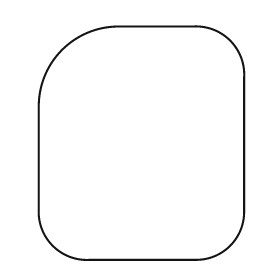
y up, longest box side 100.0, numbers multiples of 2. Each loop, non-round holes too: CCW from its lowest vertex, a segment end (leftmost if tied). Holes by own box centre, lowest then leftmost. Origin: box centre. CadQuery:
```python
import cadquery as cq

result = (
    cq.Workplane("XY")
    .moveTo(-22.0, -50.0)
    .lineTo(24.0, -50.0)
    .threePointArc((38.0, -44.0), (44.0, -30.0))
    .lineTo(44.0, 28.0)
    .threePointArc((38.0, 44.0), (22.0, 50.0))
    .lineTo(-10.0, 50.0)
    .threePointArc((-34.0, 40.0), (-44.0, 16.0))
    .lineTo(-44.0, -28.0)
    .threePointArc((-38.0, -44.0), (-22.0, -50.0))
    .close()
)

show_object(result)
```